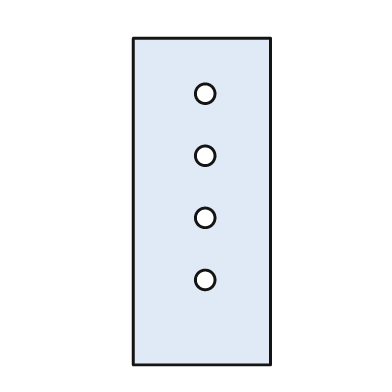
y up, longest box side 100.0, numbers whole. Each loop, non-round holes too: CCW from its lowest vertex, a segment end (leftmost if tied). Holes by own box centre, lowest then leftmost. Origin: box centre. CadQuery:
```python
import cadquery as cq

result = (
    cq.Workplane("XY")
    .moveTo(-21.0, -50.0)
    .lineTo(21.0, -50.0)
    .lineTo(21.0, 50.0)
    .lineTo(-21.0, 50.0)
    .close()
    .moveTo(1.0, -24.0)
    .circle(3.0)
    .moveTo(1.0, -5.0)
    .circle(3.0)
    .moveTo(1.0, 14.0)
    .circle(3.0)
    .moveTo(1.0, 33.0)
    .circle(3.0)
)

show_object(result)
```